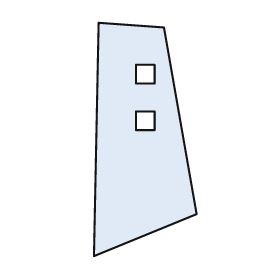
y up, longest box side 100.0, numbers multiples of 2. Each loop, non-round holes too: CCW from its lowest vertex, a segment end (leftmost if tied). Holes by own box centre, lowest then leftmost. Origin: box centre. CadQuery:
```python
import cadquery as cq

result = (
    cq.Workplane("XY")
    .moveTo(-22.0, -50.0)
    .lineTo(22.0, -32.0)
    .lineTo(8.0, 48.0)
    .lineTo(-20.0, 50.0)
    .close()
    .moveTo(-4.0, 4.0)
    .lineTo(4.0, 4.0)
    .lineTo(4.0, 12.0)
    .lineTo(-4.0, 12.0)
    .close()
    .moveTo(-4.0, 24.0)
    .lineTo(4.0, 24.0)
    .lineTo(4.0, 32.0)
    .lineTo(-4.0, 32.0)
    .close()
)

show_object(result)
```